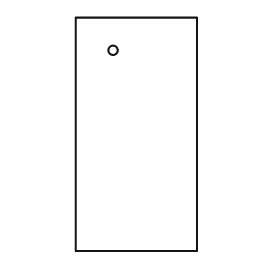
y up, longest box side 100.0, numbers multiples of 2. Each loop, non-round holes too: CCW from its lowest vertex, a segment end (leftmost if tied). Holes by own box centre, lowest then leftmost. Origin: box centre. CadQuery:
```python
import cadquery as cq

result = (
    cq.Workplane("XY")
    .moveTo(-26.0, -50.0)
    .lineTo(26.0, -50.0)
    .lineTo(26.0, 50.0)
    .lineTo(-26.0, 50.0)
    .close()
    .moveTo(-10.0, 36.0)
    .circle(2.0)
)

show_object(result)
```